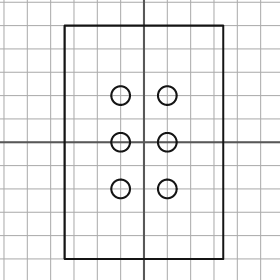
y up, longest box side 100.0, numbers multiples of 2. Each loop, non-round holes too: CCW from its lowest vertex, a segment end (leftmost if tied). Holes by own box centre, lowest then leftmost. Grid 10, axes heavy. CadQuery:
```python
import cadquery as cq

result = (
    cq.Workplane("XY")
    .moveTo(-34.0, -50.0)
    .lineTo(34.0, -50.0)
    .lineTo(34.0, 50.0)
    .lineTo(-34.0, 50.0)
    .close()
    .moveTo(-10.0, -20.0)
    .circle(4.0)
    .moveTo(10.0, -20.0)
    .circle(4.0)
    .moveTo(-10.0, 0.0)
    .circle(4.0)
    .moveTo(10.0, 0.0)
    .circle(4.0)
    .moveTo(-10.0, 20.0)
    .circle(4.0)
    .moveTo(10.0, 20.0)
    .circle(4.0)
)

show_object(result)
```